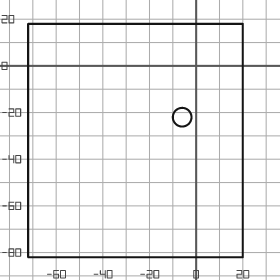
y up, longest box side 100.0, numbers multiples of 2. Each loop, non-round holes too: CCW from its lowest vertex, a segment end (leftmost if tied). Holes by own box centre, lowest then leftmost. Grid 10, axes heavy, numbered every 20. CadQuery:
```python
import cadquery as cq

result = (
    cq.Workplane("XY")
    .moveTo(-72.0, -82.0)
    .lineTo(20.0, -82.0)
    .lineTo(20.0, 18.0)
    .lineTo(-72.0, 18.0)
    .close()
    .moveTo(-6.0, -22.0)
    .circle(4.0)
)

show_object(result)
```